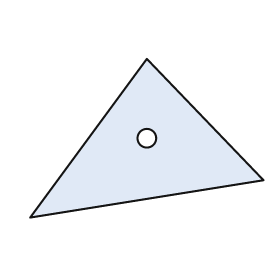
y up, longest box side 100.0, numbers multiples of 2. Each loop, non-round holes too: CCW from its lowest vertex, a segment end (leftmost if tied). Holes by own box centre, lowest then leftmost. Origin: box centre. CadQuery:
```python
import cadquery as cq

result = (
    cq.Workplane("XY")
    .moveTo(-50.0, -34.0)
    .lineTo(50.0, -18.0)
    .lineTo(0.0, 34.0)
    .close()
    .moveTo(0.0, 0.0)
    .circle(4.0)
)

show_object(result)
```